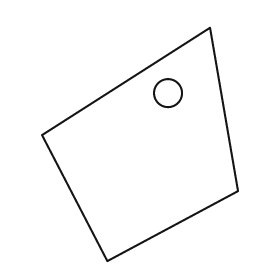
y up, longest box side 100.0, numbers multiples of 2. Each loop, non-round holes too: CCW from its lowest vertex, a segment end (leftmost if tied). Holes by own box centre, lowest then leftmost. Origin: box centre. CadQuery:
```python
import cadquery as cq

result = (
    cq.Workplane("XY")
    .moveTo(-14.0, -50.0)
    .lineTo(42.0, -20.0)
    .lineTo(30.0, 50.0)
    .lineTo(-42.0, 4.0)
    .close()
    .moveTo(12.0, 22.0)
    .circle(6.0)
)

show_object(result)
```